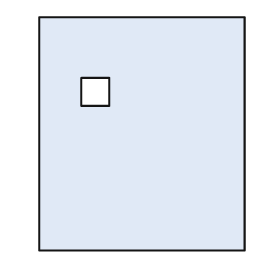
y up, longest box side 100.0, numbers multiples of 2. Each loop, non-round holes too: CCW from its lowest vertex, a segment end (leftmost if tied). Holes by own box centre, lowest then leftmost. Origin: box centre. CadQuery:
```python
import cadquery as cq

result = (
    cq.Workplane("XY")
    .moveTo(-44.0, -50.0)
    .lineTo(44.0, -50.0)
    .lineTo(44.0, 50.0)
    .lineTo(-44.0, 50.0)
    .close()
    .moveTo(-26.0, 12.0)
    .lineTo(-14.0, 12.0)
    .lineTo(-14.0, 24.0)
    .lineTo(-26.0, 24.0)
    .close()
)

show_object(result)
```